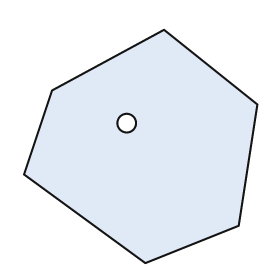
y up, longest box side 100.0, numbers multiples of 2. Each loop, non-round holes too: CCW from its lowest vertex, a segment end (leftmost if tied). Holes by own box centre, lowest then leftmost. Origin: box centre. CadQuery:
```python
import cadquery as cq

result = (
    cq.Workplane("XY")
    .moveTo(2.0, -50.0)
    .lineTo(42.0, -34.0)
    .lineTo(50.0, 18.0)
    .lineTo(10.0, 50.0)
    .lineTo(-38.0, 24.0)
    .lineTo(-50.0, -12.0)
    .close()
    .moveTo(-6.0, 10.0)
    .circle(4.0)
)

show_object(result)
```